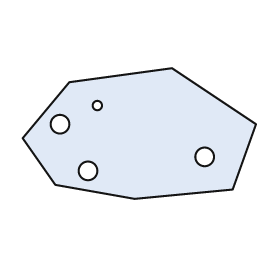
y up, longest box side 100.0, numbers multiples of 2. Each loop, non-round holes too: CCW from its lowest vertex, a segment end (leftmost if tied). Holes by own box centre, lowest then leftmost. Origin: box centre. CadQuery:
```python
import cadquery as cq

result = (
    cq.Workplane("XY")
    .moveTo(-2.0, -28.0)
    .lineTo(40.0, -24.0)
    .lineTo(50.0, 4.0)
    .lineTo(14.0, 28.0)
    .lineTo(-30.0, 22.0)
    .lineTo(-50.0, -2.0)
    .lineTo(-36.0, -22.0)
    .close()
    .moveTo(-22.0, -16.0)
    .circle(4.0)
    .moveTo(28.0, -10.0)
    .circle(4.0)
    .moveTo(-34.0, 4.0)
    .circle(4.0)
    .moveTo(-18.0, 12.0)
    .circle(2.0)
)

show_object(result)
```